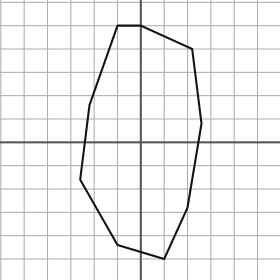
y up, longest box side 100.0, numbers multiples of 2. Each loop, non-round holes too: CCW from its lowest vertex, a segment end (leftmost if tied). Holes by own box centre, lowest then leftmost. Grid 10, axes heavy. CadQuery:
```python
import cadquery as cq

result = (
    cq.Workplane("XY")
    .moveTo(10.0, -50.0)
    .lineTo(20.0, -28.0)
    .lineTo(26.0, 8.0)
    .lineTo(22.0, 40.0)
    .lineTo(0.0, 50.0)
    .lineTo(-10.0, 50.0)
    .lineTo(-22.0, 16.0)
    .lineTo(-26.0, -16.0)
    .lineTo(-10.0, -44.0)
    .close()
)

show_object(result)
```